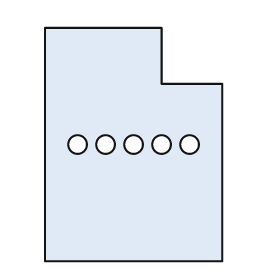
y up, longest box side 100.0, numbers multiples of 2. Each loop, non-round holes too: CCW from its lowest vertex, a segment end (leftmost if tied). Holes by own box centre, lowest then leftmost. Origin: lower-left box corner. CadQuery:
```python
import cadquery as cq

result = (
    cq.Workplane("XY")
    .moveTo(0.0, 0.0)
    .lineTo(76.0, 0.0)
    .lineTo(76.0, 76.0)
    .lineTo(50.0, 76.0)
    .lineTo(50.0, 100.0)
    .lineTo(0.0, 100.0)
    .close()
    .moveTo(14.0, 50.0)
    .circle(4.0)
    .moveTo(26.0, 50.0)
    .circle(4.0)
    .moveTo(38.0, 50.0)
    .circle(4.0)
    .moveTo(50.0, 50.0)
    .circle(4.0)
    .moveTo(62.0, 50.0)
    .circle(4.0)
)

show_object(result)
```